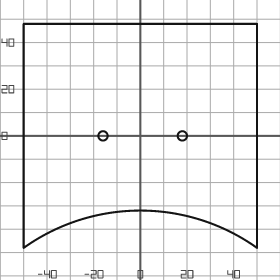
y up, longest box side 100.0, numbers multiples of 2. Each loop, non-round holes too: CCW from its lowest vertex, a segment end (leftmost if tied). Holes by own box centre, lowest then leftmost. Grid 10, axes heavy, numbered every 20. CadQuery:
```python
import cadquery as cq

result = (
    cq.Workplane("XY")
    .moveTo(-50.0, -48.0)
    .threePointArc((0.0, -32.0), (50.0, -48.0))
    .lineTo(50.0, 48.0)
    .lineTo(-50.0, 48.0)
    .close()
    .moveTo(-16.0, 0.0)
    .circle(2.0)
    .moveTo(18.0, 0.0)
    .circle(2.0)
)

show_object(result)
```